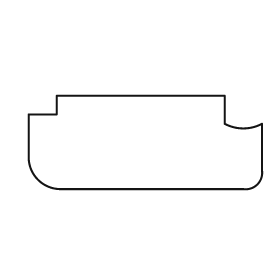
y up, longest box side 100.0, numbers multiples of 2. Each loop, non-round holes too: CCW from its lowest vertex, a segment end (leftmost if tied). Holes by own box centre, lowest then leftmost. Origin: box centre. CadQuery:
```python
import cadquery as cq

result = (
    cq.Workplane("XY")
    .moveTo(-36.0, -20.0)
    .lineTo(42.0, -20.0)
    .threePointArc((48.0, -18.0), (50.0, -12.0))
    .lineTo(50.0, 8.0)
    .threePointArc((42.0, 6.0), (34.0, 8.0))
    .lineTo(34.0, 20.0)
    .lineTo(-38.0, 20.0)
    .lineTo(-38.0, 12.0)
    .lineTo(-50.0, 12.0)
    .lineTo(-50.0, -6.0)
    .threePointArc((-46.0, -16.0), (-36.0, -20.0))
    .close()
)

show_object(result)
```